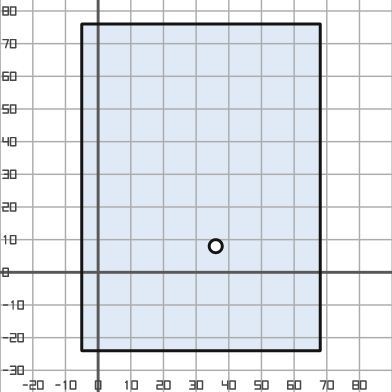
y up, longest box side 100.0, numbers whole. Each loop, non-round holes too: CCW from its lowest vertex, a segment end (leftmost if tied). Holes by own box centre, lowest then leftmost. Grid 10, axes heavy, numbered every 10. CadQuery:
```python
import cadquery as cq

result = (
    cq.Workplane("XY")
    .moveTo(-5.0, -24.0)
    .lineTo(68.0, -24.0)
    .lineTo(68.0, 76.0)
    .lineTo(-5.0, 76.0)
    .close()
    .moveTo(36.0, 8.0)
    .circle(2.0)
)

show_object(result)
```